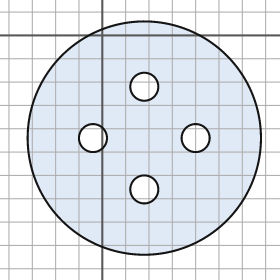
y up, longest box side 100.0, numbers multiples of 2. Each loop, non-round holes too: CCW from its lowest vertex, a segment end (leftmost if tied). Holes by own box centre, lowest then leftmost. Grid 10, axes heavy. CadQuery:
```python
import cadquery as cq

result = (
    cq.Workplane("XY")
    .moveTo(18.0, -44.0)
    .circle(50.0)
    .moveTo(18.0, -66.0)
    .circle(6.0)
    .moveTo(-4.0, -44.0)
    .circle(6.0)
    .moveTo(40.0, -44.0)
    .circle(6.0)
    .moveTo(18.0, -22.0)
    .circle(6.0)
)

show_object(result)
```